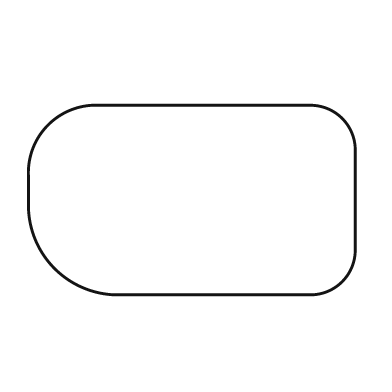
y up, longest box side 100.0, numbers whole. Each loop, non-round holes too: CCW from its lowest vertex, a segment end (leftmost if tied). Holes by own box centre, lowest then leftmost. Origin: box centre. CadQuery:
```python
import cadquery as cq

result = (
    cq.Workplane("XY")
    .moveTo(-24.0, -29.0)
    .lineTo(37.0, -29.0)
    .threePointArc((46.0, -25.0), (50.0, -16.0))
    .lineTo(50.0, 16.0)
    .threePointArc((46.0, 25.0), (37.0, 29.0))
    .lineTo(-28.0, 29.0)
    .threePointArc((-44.0, 23.0), (-50.0, 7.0))
    .lineTo(-50.0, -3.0)
    .threePointArc((-42.0, -21.0), (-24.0, -29.0))
    .close()
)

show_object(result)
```